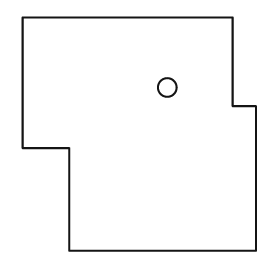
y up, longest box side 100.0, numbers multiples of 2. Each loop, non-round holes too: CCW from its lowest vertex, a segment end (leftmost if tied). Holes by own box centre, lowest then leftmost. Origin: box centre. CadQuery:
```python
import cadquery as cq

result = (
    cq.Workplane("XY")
    .moveTo(-30.0, -50.0)
    .lineTo(50.0, -50.0)
    .lineTo(50.0, 12.0)
    .lineTo(40.0, 12.0)
    .lineTo(40.0, 50.0)
    .lineTo(-50.0, 50.0)
    .lineTo(-50.0, -6.0)
    .lineTo(-30.0, -6.0)
    .close()
    .moveTo(12.0, 20.0)
    .circle(4.0)
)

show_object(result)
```